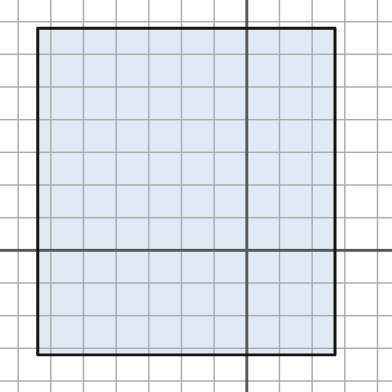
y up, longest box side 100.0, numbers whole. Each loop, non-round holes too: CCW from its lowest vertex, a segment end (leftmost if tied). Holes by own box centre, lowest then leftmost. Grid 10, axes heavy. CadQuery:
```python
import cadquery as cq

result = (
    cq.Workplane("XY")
    .moveTo(-64.0, -32.0)
    .lineTo(27.0, -32.0)
    .lineTo(27.0, 68.0)
    .lineTo(-64.0, 68.0)
    .close()
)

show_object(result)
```